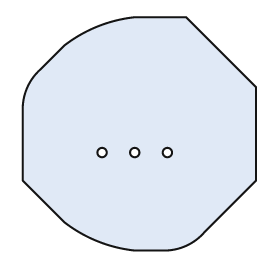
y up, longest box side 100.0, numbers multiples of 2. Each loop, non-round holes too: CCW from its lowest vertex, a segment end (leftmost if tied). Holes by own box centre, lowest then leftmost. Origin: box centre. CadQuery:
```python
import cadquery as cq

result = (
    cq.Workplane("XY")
    .moveTo(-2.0, -50.0)
    .lineTo(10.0, -50.0)
    .threePointArc((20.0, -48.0), (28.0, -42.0))
    .lineTo(50.0, -20.0)
    .lineTo(50.0, 20.0)
    .lineTo(20.0, 50.0)
    .lineTo(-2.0, 50.0)
    .threePointArc((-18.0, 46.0), (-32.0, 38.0))
    .lineTo(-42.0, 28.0)
    .threePointArc((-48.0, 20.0), (-50.0, 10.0))
    .lineTo(-50.0, -20.0)
    .lineTo(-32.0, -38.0)
    .threePointArc((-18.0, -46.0), (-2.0, -50.0))
    .close()
    .moveTo(-16.0, -8.0)
    .circle(2.0)
    .moveTo(-2.0, -8.0)
    .circle(2.0)
    .moveTo(12.0, -8.0)
    .circle(2.0)
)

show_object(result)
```